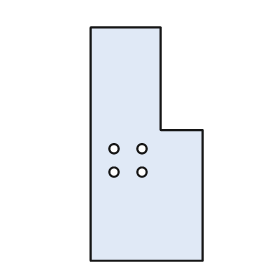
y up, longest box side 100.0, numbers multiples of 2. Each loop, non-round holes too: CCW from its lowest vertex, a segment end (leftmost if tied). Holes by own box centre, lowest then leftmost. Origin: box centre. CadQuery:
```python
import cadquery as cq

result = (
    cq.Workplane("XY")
    .moveTo(-24.0, -50.0)
    .lineTo(24.0, -50.0)
    .lineTo(24.0, 6.0)
    .lineTo(6.0, 6.0)
    .lineTo(6.0, 50.0)
    .lineTo(-24.0, 50.0)
    .close()
    .moveTo(-14.0, -12.0)
    .circle(2.0)
    .moveTo(-2.0, -12.0)
    .circle(2.0)
    .moveTo(-14.0, -2.0)
    .circle(2.0)
    .moveTo(-2.0, -2.0)
    .circle(2.0)
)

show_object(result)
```